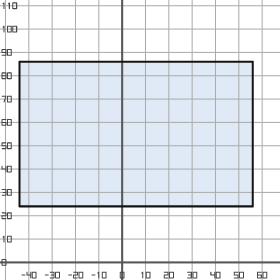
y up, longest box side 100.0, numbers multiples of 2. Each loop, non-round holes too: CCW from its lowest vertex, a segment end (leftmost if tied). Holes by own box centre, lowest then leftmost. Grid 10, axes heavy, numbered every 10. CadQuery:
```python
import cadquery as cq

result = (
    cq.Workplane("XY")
    .moveTo(-44.0, 24.0)
    .lineTo(56.0, 24.0)
    .lineTo(56.0, 86.0)
    .lineTo(-44.0, 86.0)
    .close()
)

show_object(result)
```